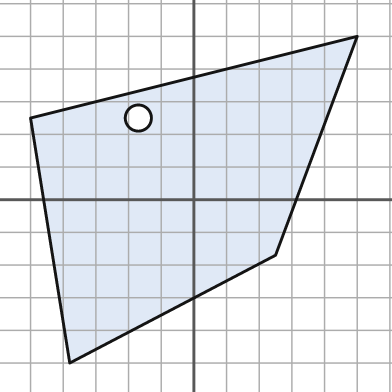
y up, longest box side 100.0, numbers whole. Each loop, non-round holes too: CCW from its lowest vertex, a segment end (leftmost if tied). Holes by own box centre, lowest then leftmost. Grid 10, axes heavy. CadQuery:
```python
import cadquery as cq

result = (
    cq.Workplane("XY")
    .moveTo(-38.0, -50.0)
    .lineTo(25.0, -17.0)
    .lineTo(50.0, 50.0)
    .lineTo(-50.0, 25.0)
    .close()
    .moveTo(-17.0, 25.0)
    .circle(4.0)
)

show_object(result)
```